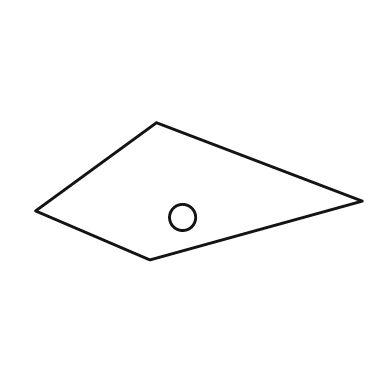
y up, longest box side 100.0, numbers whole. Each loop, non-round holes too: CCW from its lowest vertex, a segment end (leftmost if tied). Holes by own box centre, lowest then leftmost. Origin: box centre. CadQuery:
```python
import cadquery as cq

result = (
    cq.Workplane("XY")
    .moveTo(-15.0, -21.0)
    .lineTo(50.0, -3.0)
    .lineTo(-13.0, 21.0)
    .lineTo(-50.0, -6.0)
    .close()
    .moveTo(-5.0, -8.0)
    .circle(4.0)
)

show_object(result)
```